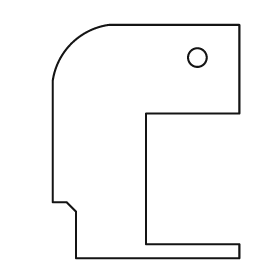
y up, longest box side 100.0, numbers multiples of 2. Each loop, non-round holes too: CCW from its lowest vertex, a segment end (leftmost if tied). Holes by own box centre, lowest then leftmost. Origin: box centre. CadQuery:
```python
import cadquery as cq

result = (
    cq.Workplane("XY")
    .moveTo(-30.0, -50.0)
    .lineTo(40.0, -50.0)
    .lineTo(40.0, -44.0)
    .lineTo(0.0, -44.0)
    .lineTo(0.0, 12.0)
    .lineTo(40.0, 12.0)
    .lineTo(40.0, 50.0)
    .lineTo(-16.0, 50.0)
    .threePointArc((-32.0, 42.0), (-40.0, 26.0))
    .lineTo(-40.0, -26.0)
    .lineTo(-34.0, -26.0)
    .lineTo(-30.0, -30.0)
    .close()
    .moveTo(22.0, 36.0)
    .circle(4.0)
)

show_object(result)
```